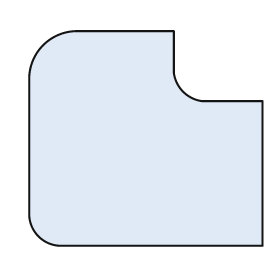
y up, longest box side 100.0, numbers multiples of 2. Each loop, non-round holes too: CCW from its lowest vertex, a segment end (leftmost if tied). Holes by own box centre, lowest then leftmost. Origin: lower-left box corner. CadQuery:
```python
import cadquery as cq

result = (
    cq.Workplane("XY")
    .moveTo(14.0, 0.0)
    .lineTo(100.0, 0.0)
    .lineTo(100.0, 62.0)
    .lineTo(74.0, 62.0)
    .threePointArc((66.0, 66.0), (62.0, 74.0))
    .lineTo(62.0, 92.0)
    .lineTo(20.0, 92.0)
    .threePointArc((6.0, 86.0), (0.0, 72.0))
    .lineTo(0.0, 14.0)
    .threePointArc((4.0, 4.0), (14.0, 0.0))
    .close()
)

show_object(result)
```